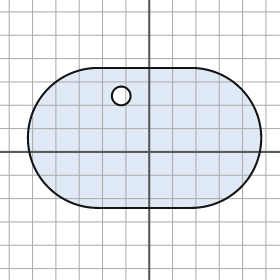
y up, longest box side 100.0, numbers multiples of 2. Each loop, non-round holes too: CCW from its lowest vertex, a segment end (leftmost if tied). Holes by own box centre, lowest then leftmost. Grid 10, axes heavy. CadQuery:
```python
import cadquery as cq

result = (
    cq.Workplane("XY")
    .moveTo(-22.0, -24.0)
    .lineTo(18.0, -24.0)
    .threePointArc((48.0, 6.0), (18.0, 36.0))
    .lineTo(-22.0, 36.0)
    .threePointArc((-52.0, 6.0), (-22.0, -24.0))
    .close()
    .moveTo(-12.0, 24.0)
    .circle(4.0)
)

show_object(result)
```